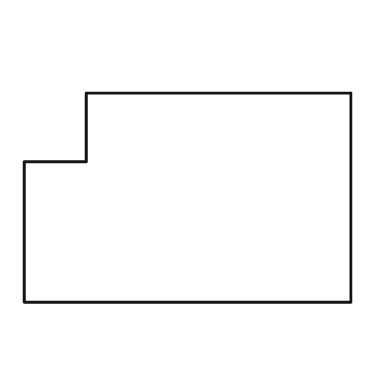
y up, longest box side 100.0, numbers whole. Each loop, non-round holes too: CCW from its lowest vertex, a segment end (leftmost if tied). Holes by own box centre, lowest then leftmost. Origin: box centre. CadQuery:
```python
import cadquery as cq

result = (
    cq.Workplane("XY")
    .moveTo(-50.0, -32.0)
    .lineTo(50.0, -32.0)
    .lineTo(50.0, 32.0)
    .lineTo(-31.0, 32.0)
    .lineTo(-31.0, 11.0)
    .lineTo(-50.0, 11.0)
    .close()
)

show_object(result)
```